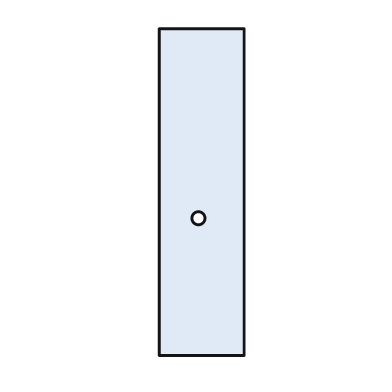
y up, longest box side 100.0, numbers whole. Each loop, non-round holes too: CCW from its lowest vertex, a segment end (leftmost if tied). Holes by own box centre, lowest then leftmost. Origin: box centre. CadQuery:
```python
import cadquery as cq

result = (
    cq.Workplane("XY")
    .moveTo(-13.0, -50.0)
    .lineTo(13.0, -50.0)
    .lineTo(13.0, 50.0)
    .lineTo(-13.0, 50.0)
    .close()
    .moveTo(-1.0, -8.0)
    .circle(2.0)
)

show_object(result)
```